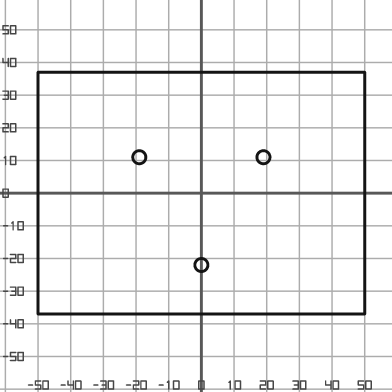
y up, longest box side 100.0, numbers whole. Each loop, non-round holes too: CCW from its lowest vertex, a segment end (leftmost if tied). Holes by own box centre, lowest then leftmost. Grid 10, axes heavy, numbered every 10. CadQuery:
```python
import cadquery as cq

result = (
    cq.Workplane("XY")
    .moveTo(-50.0, -37.0)
    .lineTo(50.0, -37.0)
    .lineTo(50.0, 37.0)
    .lineTo(-50.0, 37.0)
    .close()
    .moveTo(0.0, -22.0)
    .circle(2.0)
    .moveTo(-19.0, 11.0)
    .circle(2.0)
    .moveTo(19.0, 11.0)
    .circle(2.0)
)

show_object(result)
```